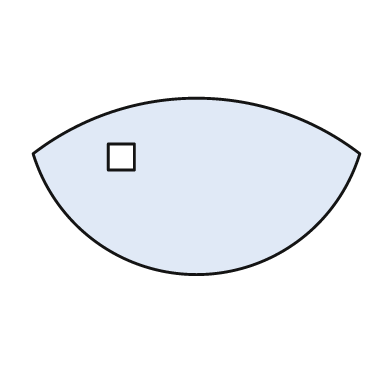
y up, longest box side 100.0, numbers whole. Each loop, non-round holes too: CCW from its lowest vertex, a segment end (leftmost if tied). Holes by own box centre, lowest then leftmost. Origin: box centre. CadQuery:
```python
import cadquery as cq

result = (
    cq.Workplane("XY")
    .moveTo(-50.0, 10.0)
    .threePointArc((0.0, -27.0), (50.0, 10.0))
    .threePointArc((0.0, 27.0), (-50.0, 10.0))
    .close()
    .moveTo(-27.0, 5.0)
    .lineTo(-19.0, 5.0)
    .lineTo(-19.0, 13.0)
    .lineTo(-27.0, 13.0)
    .close()
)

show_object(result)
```